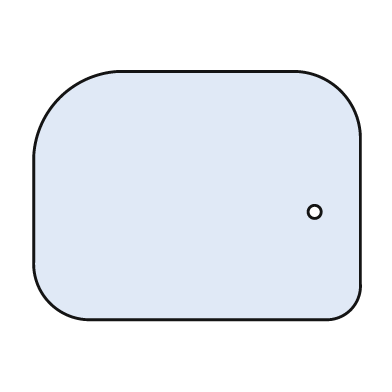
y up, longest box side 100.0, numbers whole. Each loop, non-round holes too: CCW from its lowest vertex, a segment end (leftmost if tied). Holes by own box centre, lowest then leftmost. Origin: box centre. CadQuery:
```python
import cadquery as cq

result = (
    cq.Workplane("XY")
    .moveTo(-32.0, -38.0)
    .lineTo(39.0, -38.0)
    .threePointArc((47.0, -35.0), (50.0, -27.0))
    .lineTo(50.0, 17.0)
    .threePointArc((44.0, 32.0), (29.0, 38.0))
    .lineTo(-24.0, 38.0)
    .threePointArc((-42.0, 30.0), (-50.0, 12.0))
    .lineTo(-50.0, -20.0)
    .threePointArc((-45.0, -33.0), (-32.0, -38.0))
    .close()
    .moveTo(36.0, -5.0)
    .circle(2.0)
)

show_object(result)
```